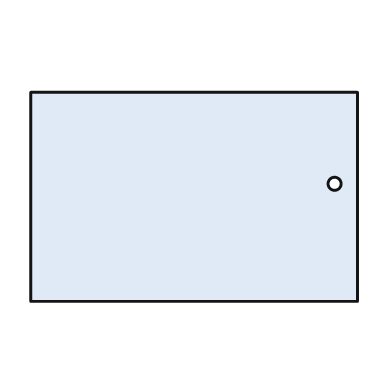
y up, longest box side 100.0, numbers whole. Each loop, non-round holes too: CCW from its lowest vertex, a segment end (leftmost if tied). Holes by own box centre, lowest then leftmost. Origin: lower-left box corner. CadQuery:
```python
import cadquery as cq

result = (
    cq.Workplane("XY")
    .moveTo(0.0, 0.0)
    .lineTo(100.0, 0.0)
    .lineTo(100.0, 64.0)
    .lineTo(0.0, 64.0)
    .close()
    .moveTo(93.0, 36.0)
    .circle(2.0)
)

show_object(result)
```